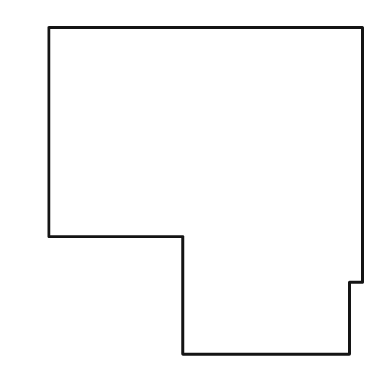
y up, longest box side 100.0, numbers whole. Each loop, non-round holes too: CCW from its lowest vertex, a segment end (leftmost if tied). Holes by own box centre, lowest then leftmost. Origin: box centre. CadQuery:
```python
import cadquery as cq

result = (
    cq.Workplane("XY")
    .moveTo(-7.0, -50.0)
    .lineTo(44.0, -50.0)
    .lineTo(44.0, -28.0)
    .lineTo(48.0, -28.0)
    .lineTo(48.0, 50.0)
    .lineTo(-48.0, 50.0)
    .lineTo(-48.0, -14.0)
    .lineTo(-7.0, -14.0)
    .close()
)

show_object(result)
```